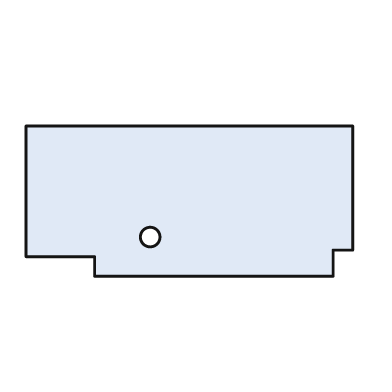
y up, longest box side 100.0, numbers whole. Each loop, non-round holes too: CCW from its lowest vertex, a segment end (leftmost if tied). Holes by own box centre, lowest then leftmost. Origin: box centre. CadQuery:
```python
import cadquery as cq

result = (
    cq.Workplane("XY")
    .moveTo(-29.0, -23.0)
    .lineTo(44.0, -23.0)
    .lineTo(44.0, -15.0)
    .lineTo(50.0, -15.0)
    .lineTo(50.0, 23.0)
    .lineTo(-50.0, 23.0)
    .lineTo(-50.0, -17.0)
    .lineTo(-29.0, -17.0)
    .close()
    .moveTo(-12.0, -11.0)
    .circle(3.0)
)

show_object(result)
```